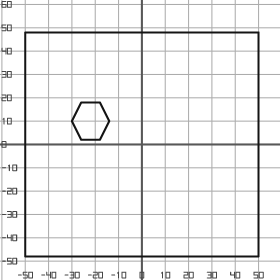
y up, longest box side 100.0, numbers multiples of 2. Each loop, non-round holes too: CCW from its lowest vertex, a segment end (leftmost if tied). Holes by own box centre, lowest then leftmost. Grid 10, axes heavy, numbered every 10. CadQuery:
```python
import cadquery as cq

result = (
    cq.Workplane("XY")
    .moveTo(-50.0, -48.0)
    .lineTo(50.0, -48.0)
    .lineTo(50.0, 48.0)
    .lineTo(-50.0, 48.0)
    .close()
    .moveTo(-26.0, 2.0)
    .lineTo(-18.0, 2.0)
    .lineTo(-14.0, 10.0)
    .lineTo(-18.0, 18.0)
    .lineTo(-26.0, 18.0)
    .lineTo(-30.0, 10.0)
    .close()
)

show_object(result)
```